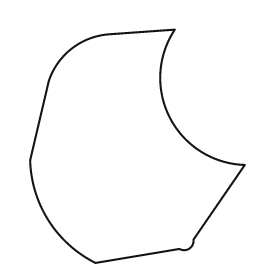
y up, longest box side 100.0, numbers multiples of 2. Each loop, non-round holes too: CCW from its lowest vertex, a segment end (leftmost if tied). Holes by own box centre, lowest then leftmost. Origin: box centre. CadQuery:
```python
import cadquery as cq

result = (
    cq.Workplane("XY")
    .moveTo(-18.0, -50.0)
    .lineTo(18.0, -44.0)
    .threePointArc((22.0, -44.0), (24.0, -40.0))
    .lineTo(46.0, -8.0)
    .threePointArc((14.0, 12.0), (16.0, 50.0))
    .lineTo(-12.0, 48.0)
    .threePointArc((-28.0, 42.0), (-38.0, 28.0))
    .lineTo(-46.0, -6.0)
    .threePointArc((-38.0, -32.0), (-18.0, -50.0))
    .close()
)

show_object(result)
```